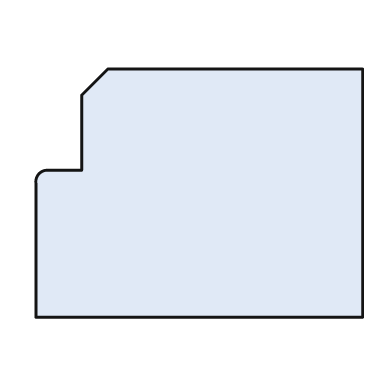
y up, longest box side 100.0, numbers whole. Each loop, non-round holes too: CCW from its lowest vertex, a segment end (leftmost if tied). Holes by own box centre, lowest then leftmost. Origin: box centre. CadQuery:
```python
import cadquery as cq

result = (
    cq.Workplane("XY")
    .moveTo(-50.0, -38.0)
    .lineTo(50.0, -38.0)
    .lineTo(50.0, 38.0)
    .lineTo(-28.0, 38.0)
    .lineTo(-36.0, 30.0)
    .lineTo(-36.0, 7.0)
    .lineTo(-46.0, 7.0)
    .threePointArc((-49.0, 6.0), (-50.0, 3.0))
    .close()
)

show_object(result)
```